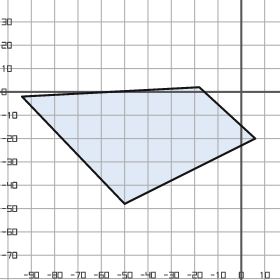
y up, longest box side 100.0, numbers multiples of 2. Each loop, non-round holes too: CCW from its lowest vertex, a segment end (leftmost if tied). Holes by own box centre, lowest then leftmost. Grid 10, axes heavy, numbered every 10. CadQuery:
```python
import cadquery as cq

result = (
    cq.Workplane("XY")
    .moveTo(-50.0, -48.0)
    .lineTo(6.0, -20.0)
    .lineTo(-18.0, 2.0)
    .lineTo(-94.0, -2.0)
    .close()
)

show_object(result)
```